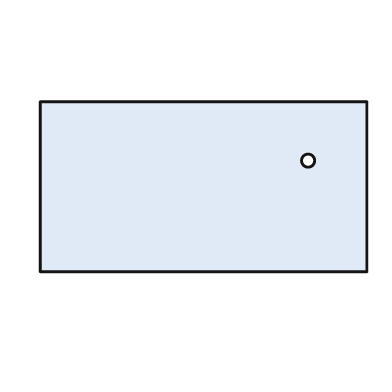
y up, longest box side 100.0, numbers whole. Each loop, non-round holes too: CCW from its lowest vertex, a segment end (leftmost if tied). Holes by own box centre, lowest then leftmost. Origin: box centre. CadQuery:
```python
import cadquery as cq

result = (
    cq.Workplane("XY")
    .moveTo(-50.0, -26.0)
    .lineTo(50.0, -26.0)
    .lineTo(50.0, 26.0)
    .lineTo(-50.0, 26.0)
    .close()
    .moveTo(32.0, 8.0)
    .circle(2.0)
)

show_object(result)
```